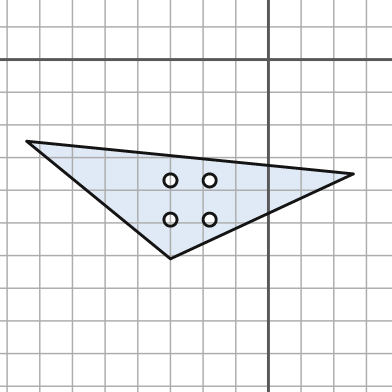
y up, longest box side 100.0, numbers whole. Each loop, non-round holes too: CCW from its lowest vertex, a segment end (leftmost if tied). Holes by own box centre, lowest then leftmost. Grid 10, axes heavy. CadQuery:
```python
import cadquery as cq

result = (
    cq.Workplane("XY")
    .moveTo(-30.0, -61.0)
    .lineTo(26.0, -35.0)
    .lineTo(-74.0, -25.0)
    .close()
    .moveTo(-30.0, -49.0)
    .circle(2.0)
    .moveTo(-18.0, -49.0)
    .circle(2.0)
    .moveTo(-30.0, -37.0)
    .circle(2.0)
    .moveTo(-18.0, -37.0)
    .circle(2.0)
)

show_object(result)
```